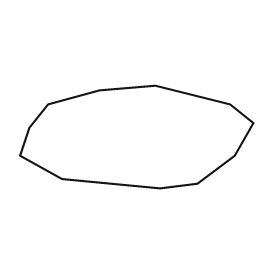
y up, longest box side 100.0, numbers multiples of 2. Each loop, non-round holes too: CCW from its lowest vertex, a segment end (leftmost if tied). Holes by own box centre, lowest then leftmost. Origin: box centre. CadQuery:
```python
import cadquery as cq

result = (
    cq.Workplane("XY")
    .moveTo(10.0, -22.0)
    .lineTo(26.0, -20.0)
    .lineTo(42.0, -8.0)
    .lineTo(50.0, 6.0)
    .lineTo(40.0, 14.0)
    .lineTo(8.0, 22.0)
    .lineTo(-16.0, 20.0)
    .lineTo(-38.0, 14.0)
    .lineTo(-46.0, 4.0)
    .lineTo(-50.0, -8.0)
    .lineTo(-32.0, -18.0)
    .close()
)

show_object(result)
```